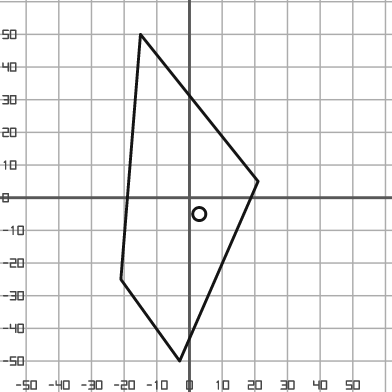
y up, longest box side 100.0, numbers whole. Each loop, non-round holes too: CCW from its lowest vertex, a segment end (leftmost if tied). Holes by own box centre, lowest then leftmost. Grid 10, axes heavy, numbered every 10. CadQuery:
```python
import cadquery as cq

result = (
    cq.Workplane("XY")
    .moveTo(-3.0, -50.0)
    .lineTo(21.0, 5.0)
    .lineTo(-15.0, 50.0)
    .lineTo(-21.0, -25.0)
    .close()
    .moveTo(3.0, -5.0)
    .circle(2.0)
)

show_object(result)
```